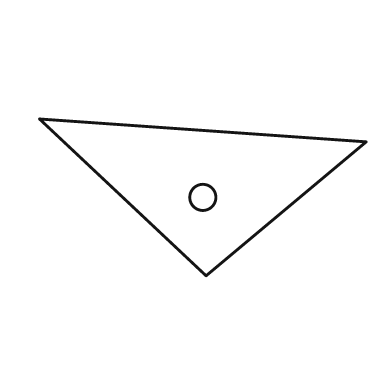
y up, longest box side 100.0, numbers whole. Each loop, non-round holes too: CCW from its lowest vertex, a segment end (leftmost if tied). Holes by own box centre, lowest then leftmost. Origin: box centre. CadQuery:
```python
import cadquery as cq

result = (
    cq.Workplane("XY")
    .moveTo(1.0, -24.0)
    .lineTo(50.0, 17.0)
    .lineTo(-50.0, 24.0)
    .close()
    .moveTo(0.0, 0.0)
    .circle(4.0)
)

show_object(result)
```